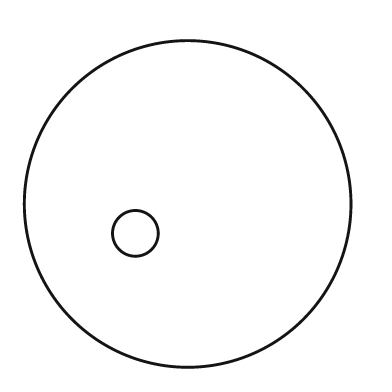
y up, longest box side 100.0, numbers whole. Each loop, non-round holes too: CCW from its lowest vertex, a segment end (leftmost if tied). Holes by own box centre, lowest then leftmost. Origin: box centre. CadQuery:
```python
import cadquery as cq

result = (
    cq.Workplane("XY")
    .moveTo(0.0, 0.0)
    .circle(50.0)
    .moveTo(-16.0, -9.0)
    .circle(7.0)
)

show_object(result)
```